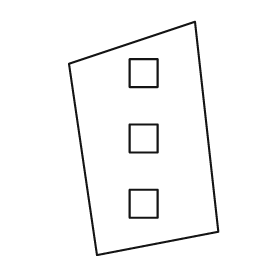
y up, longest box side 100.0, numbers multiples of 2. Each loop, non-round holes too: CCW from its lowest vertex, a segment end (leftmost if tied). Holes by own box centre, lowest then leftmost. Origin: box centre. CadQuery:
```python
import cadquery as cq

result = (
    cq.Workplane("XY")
    .moveTo(-20.0, -50.0)
    .lineTo(32.0, -40.0)
    .lineTo(22.0, 50.0)
    .lineTo(-32.0, 32.0)
    .close()
    .moveTo(-6.0, -34.0)
    .lineTo(6.0, -34.0)
    .lineTo(6.0, -22.0)
    .lineTo(-6.0, -22.0)
    .close()
    .moveTo(-6.0, -6.0)
    .lineTo(6.0, -6.0)
    .lineTo(6.0, 6.0)
    .lineTo(-6.0, 6.0)
    .close()
    .moveTo(-6.0, 22.0)
    .lineTo(6.0, 22.0)
    .lineTo(6.0, 34.0)
    .lineTo(-6.0, 34.0)
    .close()
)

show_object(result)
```